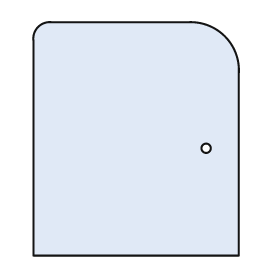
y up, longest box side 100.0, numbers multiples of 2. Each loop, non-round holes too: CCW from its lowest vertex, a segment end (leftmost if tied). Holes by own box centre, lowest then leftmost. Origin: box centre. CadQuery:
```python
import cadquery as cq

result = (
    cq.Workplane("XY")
    .moveTo(-44.0, -50.0)
    .lineTo(44.0, -50.0)
    .lineTo(44.0, 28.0)
    .threePointArc((38.0, 44.0), (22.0, 50.0))
    .lineTo(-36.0, 50.0)
    .threePointArc((-42.0, 48.0), (-44.0, 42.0))
    .close()
    .moveTo(30.0, -4.0)
    .circle(2.0)
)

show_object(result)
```